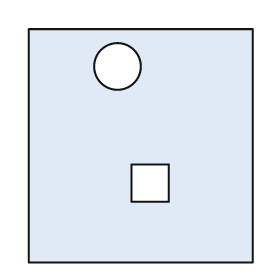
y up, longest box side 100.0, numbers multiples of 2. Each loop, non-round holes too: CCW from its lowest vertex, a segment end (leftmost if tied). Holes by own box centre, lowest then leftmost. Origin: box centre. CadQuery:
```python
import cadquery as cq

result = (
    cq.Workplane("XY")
    .moveTo(-48.0, -50.0)
    .lineTo(48.0, -50.0)
    .lineTo(48.0, 50.0)
    .lineTo(-48.0, 50.0)
    .close()
    .moveTo(-4.0, -24.0)
    .lineTo(12.0, -24.0)
    .lineTo(12.0, -8.0)
    .lineTo(-4.0, -8.0)
    .close()
    .moveTo(-10.0, 34.0)
    .circle(10.0)
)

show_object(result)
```